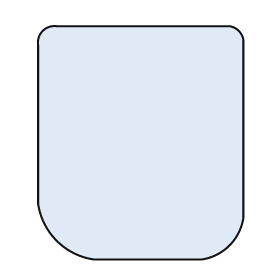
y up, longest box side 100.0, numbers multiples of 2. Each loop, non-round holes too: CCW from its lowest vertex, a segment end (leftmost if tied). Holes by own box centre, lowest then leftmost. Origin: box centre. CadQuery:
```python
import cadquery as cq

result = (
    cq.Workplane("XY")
    .moveTo(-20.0, -50.0)
    .lineTo(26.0, -50.0)
    .threePointArc((38.0, -44.0), (44.0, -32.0))
    .lineTo(44.0, 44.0)
    .threePointArc((42.0, 48.0), (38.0, 50.0))
    .lineTo(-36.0, 50.0)
    .threePointArc((-42.0, 48.0), (-44.0, 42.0))
    .lineTo(-44.0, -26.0)
    .threePointArc((-36.0, -42.0), (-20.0, -50.0))
    .close()
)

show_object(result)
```